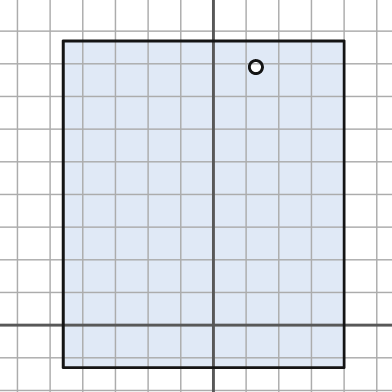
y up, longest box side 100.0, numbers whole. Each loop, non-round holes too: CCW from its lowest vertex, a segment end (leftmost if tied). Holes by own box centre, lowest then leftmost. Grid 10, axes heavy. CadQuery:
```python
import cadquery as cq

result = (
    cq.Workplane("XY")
    .moveTo(-46.0, -13.0)
    .lineTo(40.0, -13.0)
    .lineTo(40.0, 87.0)
    .lineTo(-46.0, 87.0)
    .close()
    .moveTo(13.0, 79.0)
    .circle(2.0)
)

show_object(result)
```